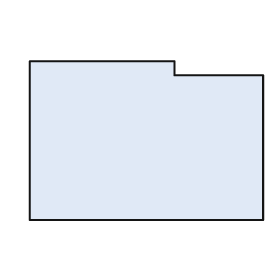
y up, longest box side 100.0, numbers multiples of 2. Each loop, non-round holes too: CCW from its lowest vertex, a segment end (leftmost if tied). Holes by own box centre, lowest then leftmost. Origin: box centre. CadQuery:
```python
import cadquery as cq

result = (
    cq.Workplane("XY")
    .moveTo(-50.0, -34.0)
    .lineTo(50.0, -34.0)
    .lineTo(50.0, 28.0)
    .lineTo(12.0, 28.0)
    .lineTo(12.0, 34.0)
    .lineTo(-50.0, 34.0)
    .close()
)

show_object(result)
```